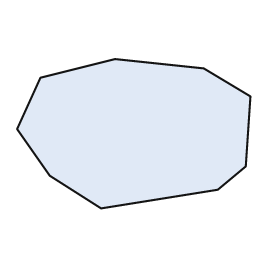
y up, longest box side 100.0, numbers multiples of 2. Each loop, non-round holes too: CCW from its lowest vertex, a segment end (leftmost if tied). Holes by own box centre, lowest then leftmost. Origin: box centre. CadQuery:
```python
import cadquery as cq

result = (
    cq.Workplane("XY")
    .moveTo(-14.0, -32.0)
    .lineTo(36.0, -24.0)
    .lineTo(48.0, -14.0)
    .lineTo(50.0, 16.0)
    .lineTo(30.0, 28.0)
    .lineTo(-8.0, 32.0)
    .lineTo(-40.0, 24.0)
    .lineTo(-50.0, 2.0)
    .lineTo(-36.0, -18.0)
    .close()
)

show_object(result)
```